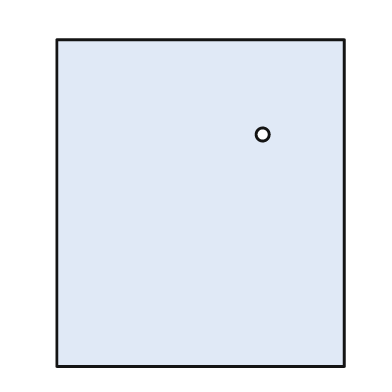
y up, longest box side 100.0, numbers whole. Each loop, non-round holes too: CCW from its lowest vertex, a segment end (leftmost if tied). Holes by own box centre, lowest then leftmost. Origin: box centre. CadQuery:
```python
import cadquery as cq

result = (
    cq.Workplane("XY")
    .moveTo(-44.0, -50.0)
    .lineTo(44.0, -50.0)
    .lineTo(44.0, 50.0)
    .lineTo(-44.0, 50.0)
    .close()
    .moveTo(19.0, 21.0)
    .circle(2.0)
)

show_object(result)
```